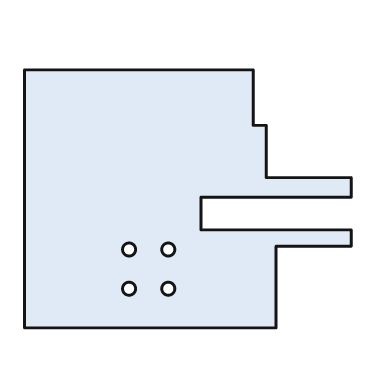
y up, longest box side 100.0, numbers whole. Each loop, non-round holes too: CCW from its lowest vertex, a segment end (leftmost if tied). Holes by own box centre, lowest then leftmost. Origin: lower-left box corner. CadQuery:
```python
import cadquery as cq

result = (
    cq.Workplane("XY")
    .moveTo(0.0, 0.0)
    .lineTo(77.0, 0.0)
    .lineTo(77.0, 25.0)
    .lineTo(100.0, 25.0)
    .lineTo(100.0, 30.0)
    .lineTo(54.0, 30.0)
    .lineTo(54.0, 40.0)
    .lineTo(100.0, 40.0)
    .lineTo(100.0, 46.0)
    .lineTo(74.0, 46.0)
    .lineTo(74.0, 62.0)
    .lineTo(70.0, 62.0)
    .lineTo(70.0, 79.0)
    .lineTo(0.0, 79.0)
    .close()
    .moveTo(32.0, 12.0)
    .circle(2.0)
    .moveTo(44.0, 12.0)
    .circle(2.0)
    .moveTo(32.0, 24.0)
    .circle(2.0)
    .moveTo(44.0, 24.0)
    .circle(2.0)
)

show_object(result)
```